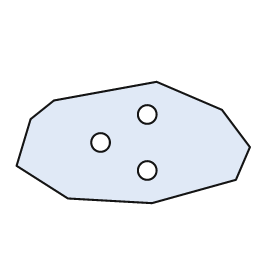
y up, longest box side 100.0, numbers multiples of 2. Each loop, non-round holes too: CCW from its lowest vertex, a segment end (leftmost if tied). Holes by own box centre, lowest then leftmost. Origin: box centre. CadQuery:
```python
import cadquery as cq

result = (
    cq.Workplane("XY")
    .moveTo(8.0, -26.0)
    .lineTo(44.0, -16.0)
    .lineTo(50.0, -2.0)
    .lineTo(38.0, 14.0)
    .lineTo(10.0, 26.0)
    .lineTo(-34.0, 18.0)
    .lineTo(-44.0, 10.0)
    .lineTo(-50.0, -10.0)
    .lineTo(-28.0, -24.0)
    .close()
    .moveTo(6.0, -12.0)
    .circle(4.0)
    .moveTo(-14.0, 0.0)
    .circle(4.0)
    .moveTo(6.0, 12.0)
    .circle(4.0)
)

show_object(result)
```